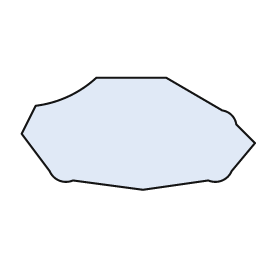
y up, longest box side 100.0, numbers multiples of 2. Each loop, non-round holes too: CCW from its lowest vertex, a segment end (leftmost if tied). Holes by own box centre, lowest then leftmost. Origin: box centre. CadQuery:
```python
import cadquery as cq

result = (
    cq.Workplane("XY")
    .moveTo(2.0, -24.0)
    .lineTo(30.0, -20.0)
    .threePointArc((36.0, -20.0), (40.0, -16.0))
    .lineTo(50.0, -4.0)
    .lineTo(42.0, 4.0)
    .threePointArc((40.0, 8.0), (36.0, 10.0))
    .lineTo(12.0, 24.0)
    .lineTo(-18.0, 24.0)
    .threePointArc((-30.0, 16.0), (-44.0, 12.0))
    .lineTo(-50.0, 0.0)
    .lineTo(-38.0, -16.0)
    .threePointArc((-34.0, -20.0), (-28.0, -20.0))
    .close()
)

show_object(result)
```